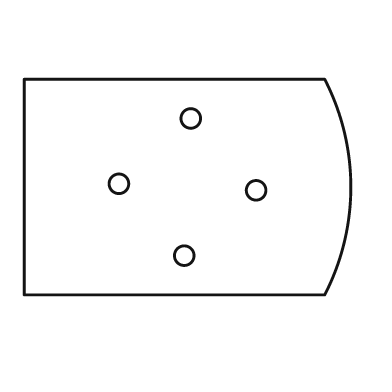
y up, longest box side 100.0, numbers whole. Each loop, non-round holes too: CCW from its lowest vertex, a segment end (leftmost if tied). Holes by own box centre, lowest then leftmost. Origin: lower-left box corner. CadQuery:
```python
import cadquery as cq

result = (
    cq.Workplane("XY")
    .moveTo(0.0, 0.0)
    .lineTo(92.0, 0.0)
    .threePointArc((100.0, 33.0), (92.0, 66.0))
    .lineTo(0.0, 66.0)
    .close()
    .moveTo(49.0, 12.0)
    .circle(3.0)
    .moveTo(71.0, 32.0)
    .circle(3.0)
    .moveTo(29.0, 34.0)
    .circle(3.0)
    .moveTo(51.0, 54.0)
    .circle(3.0)
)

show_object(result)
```